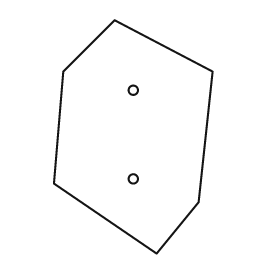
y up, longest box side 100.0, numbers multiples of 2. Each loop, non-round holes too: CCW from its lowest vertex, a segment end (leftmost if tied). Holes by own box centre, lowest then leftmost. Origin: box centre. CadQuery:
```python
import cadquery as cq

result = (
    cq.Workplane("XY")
    .moveTo(10.0, -50.0)
    .lineTo(28.0, -28.0)
    .lineTo(34.0, 28.0)
    .lineTo(-8.0, 50.0)
    .lineTo(-30.0, 28.0)
    .lineTo(-34.0, -20.0)
    .close()
    .moveTo(0.0, -18.0)
    .circle(2.0)
    .moveTo(0.0, 20.0)
    .circle(2.0)
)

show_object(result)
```